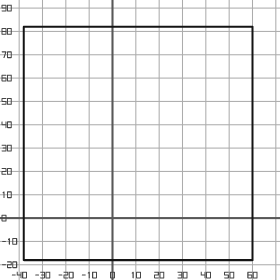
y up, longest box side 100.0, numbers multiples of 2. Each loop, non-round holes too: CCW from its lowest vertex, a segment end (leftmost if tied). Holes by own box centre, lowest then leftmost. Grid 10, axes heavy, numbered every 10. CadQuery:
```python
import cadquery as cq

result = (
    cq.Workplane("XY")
    .moveTo(-38.0, -18.0)
    .lineTo(60.0, -18.0)
    .lineTo(60.0, 82.0)
    .lineTo(-38.0, 82.0)
    .close()
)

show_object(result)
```